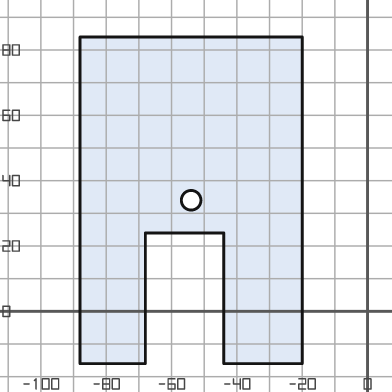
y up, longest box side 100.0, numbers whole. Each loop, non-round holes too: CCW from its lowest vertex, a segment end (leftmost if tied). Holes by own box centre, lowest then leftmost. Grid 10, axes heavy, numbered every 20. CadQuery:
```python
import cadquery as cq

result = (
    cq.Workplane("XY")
    .moveTo(-88.0, -16.0)
    .lineTo(-68.0, -16.0)
    .lineTo(-68.0, 24.0)
    .lineTo(-44.0, 24.0)
    .lineTo(-44.0, -16.0)
    .lineTo(-20.0, -16.0)
    .lineTo(-20.0, 84.0)
    .lineTo(-88.0, 84.0)
    .close()
    .moveTo(-54.0, 34.0)
    .circle(3.0)
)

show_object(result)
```